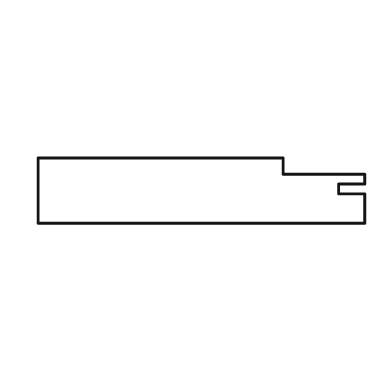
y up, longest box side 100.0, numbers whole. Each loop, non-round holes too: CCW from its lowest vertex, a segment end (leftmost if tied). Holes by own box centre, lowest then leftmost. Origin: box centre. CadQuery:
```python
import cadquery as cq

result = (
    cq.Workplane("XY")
    .moveTo(-50.0, -10.0)
    .lineTo(50.0, -10.0)
    .lineTo(50.0, -1.0)
    .lineTo(42.0, -1.0)
    .lineTo(42.0, 2.0)
    .lineTo(50.0, 2.0)
    .lineTo(50.0, 5.0)
    .lineTo(25.0, 5.0)
    .lineTo(25.0, 10.0)
    .lineTo(-50.0, 10.0)
    .close()
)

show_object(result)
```